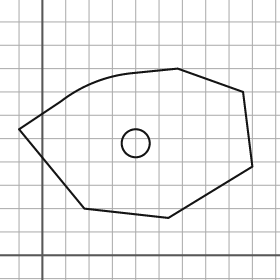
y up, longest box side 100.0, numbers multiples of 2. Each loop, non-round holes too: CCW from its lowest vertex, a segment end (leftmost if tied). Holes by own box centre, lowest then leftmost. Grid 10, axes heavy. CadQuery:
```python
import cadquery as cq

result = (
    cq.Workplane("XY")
    .moveTo(54.0, 16.0)
    .lineTo(90.0, 38.0)
    .lineTo(86.0, 70.0)
    .lineTo(58.0, 80.0)
    .lineTo(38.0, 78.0)
    .threePointArc((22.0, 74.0), (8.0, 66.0))
    .lineTo(-10.0, 54.0)
    .lineTo(18.0, 20.0)
    .close()
    .moveTo(40.0, 48.0)
    .circle(6.0)
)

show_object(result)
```